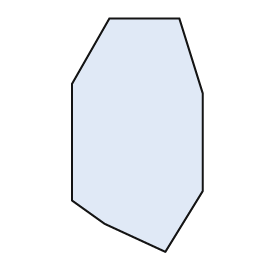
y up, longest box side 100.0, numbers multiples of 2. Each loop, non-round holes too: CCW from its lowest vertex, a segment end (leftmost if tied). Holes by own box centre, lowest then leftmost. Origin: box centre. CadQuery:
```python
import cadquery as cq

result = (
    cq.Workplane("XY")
    .moveTo(12.0, -50.0)
    .lineTo(28.0, -24.0)
    .lineTo(28.0, 18.0)
    .lineTo(18.0, 50.0)
    .lineTo(-12.0, 50.0)
    .lineTo(-28.0, 22.0)
    .lineTo(-28.0, -28.0)
    .lineTo(-14.0, -38.0)
    .close()
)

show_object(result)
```